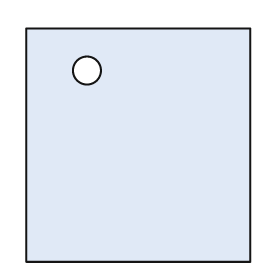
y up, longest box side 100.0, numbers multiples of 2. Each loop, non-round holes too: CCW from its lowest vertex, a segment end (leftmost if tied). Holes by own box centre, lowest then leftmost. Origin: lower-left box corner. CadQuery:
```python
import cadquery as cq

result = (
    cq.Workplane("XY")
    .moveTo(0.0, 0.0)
    .lineTo(96.0, 0.0)
    .lineTo(96.0, 100.0)
    .lineTo(0.0, 100.0)
    .close()
    .moveTo(26.0, 82.0)
    .circle(6.0)
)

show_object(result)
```